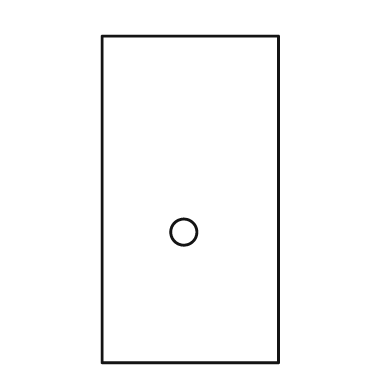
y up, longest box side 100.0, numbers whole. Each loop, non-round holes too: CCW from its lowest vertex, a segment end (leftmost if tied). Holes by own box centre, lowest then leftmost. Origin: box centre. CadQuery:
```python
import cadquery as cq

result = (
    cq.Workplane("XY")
    .moveTo(-27.0, -50.0)
    .lineTo(27.0, -50.0)
    .lineTo(27.0, 50.0)
    .lineTo(-27.0, 50.0)
    .close()
    .moveTo(-2.0, -10.0)
    .circle(4.0)
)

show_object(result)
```